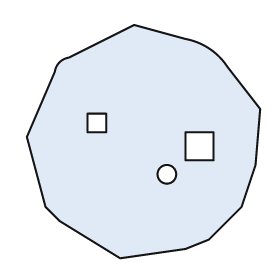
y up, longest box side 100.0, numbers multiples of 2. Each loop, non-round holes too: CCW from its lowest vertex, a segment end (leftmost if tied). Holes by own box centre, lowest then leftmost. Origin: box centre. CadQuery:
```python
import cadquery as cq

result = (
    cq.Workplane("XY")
    .moveTo(-10.0, -50.0)
    .lineTo(18.0, -46.0)
    .lineTo(28.0, -42.0)
    .lineTo(42.0, -28.0)
    .lineTo(48.0, -10.0)
    .lineTo(50.0, 14.0)
    .lineTo(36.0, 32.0)
    .threePointArc((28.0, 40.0), (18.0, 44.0))
    .lineTo(-4.0, 50.0)
    .lineTo(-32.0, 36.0)
    .threePointArc((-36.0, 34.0), (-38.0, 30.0))
    .lineTo(-50.0, 2.0)
    .lineTo(-42.0, -28.0)
    .lineTo(-36.0, -34.0)
    .close()
    .moveTo(10.0, -14.0)
    .circle(4.0)
    .moveTo(18.0, -8.0)
    .lineTo(30.0, -8.0)
    .lineTo(30.0, 4.0)
    .lineTo(18.0, 4.0)
    .close()
    .moveTo(-24.0, 4.0)
    .lineTo(-16.0, 4.0)
    .lineTo(-16.0, 12.0)
    .lineTo(-24.0, 12.0)
    .close()
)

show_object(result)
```